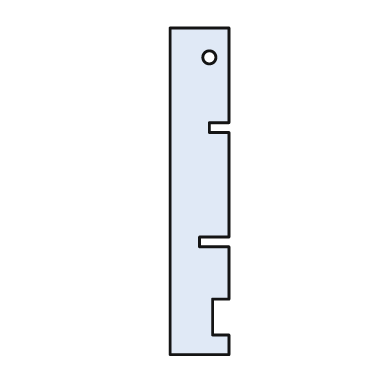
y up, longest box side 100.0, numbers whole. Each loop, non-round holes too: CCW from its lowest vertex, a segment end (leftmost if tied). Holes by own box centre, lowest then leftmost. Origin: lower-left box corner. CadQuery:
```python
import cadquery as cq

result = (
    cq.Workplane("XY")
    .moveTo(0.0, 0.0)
    .lineTo(18.0, 0.0)
    .lineTo(18.0, 6.0)
    .lineTo(13.0, 6.0)
    .lineTo(13.0, 17.0)
    .lineTo(18.0, 17.0)
    .lineTo(18.0, 33.0)
    .lineTo(9.0, 33.0)
    .lineTo(9.0, 36.0)
    .lineTo(18.0, 36.0)
    .lineTo(18.0, 68.0)
    .lineTo(12.0, 68.0)
    .lineTo(12.0, 71.0)
    .lineTo(18.0, 71.0)
    .lineTo(18.0, 100.0)
    .lineTo(0.0, 100.0)
    .close()
    .moveTo(12.0, 91.0)
    .circle(2.0)
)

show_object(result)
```